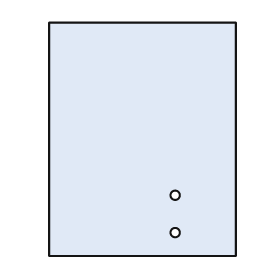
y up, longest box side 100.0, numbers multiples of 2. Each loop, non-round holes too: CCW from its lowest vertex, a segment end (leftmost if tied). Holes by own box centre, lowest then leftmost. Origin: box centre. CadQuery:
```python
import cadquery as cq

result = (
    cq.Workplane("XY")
    .moveTo(-40.0, -50.0)
    .lineTo(40.0, -50.0)
    .lineTo(40.0, 50.0)
    .lineTo(-40.0, 50.0)
    .close()
    .moveTo(14.0, -40.0)
    .circle(2.0)
    .moveTo(14.0, -24.0)
    .circle(2.0)
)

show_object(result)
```